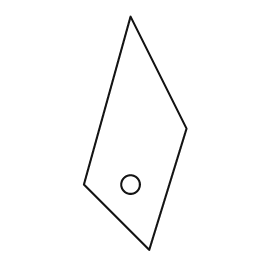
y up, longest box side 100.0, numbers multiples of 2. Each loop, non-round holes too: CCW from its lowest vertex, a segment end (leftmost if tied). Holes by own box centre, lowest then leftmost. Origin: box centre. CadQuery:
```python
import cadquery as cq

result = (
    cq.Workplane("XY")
    .moveTo(6.0, -50.0)
    .lineTo(22.0, 2.0)
    .lineTo(-2.0, 50.0)
    .lineTo(-22.0, -22.0)
    .close()
    .moveTo(-2.0, -22.0)
    .circle(4.0)
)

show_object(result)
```